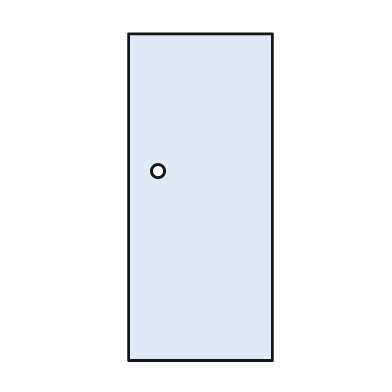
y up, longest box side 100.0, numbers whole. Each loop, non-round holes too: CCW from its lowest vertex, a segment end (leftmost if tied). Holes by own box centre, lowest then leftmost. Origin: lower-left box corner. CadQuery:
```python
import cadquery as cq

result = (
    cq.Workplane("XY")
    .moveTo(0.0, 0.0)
    .lineTo(44.0, 0.0)
    .lineTo(44.0, 100.0)
    .lineTo(0.0, 100.0)
    .close()
    .moveTo(9.0, 58.0)
    .circle(2.0)
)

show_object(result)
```